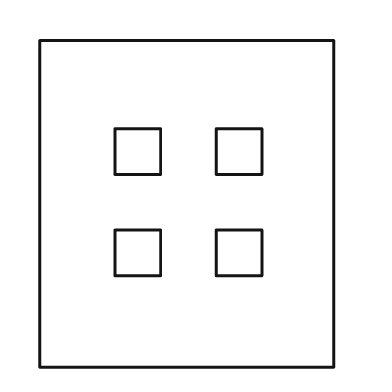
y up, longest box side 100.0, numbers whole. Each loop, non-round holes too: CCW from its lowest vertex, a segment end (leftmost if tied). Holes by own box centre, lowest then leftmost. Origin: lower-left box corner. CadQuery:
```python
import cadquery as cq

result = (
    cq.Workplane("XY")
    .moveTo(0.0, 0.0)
    .lineTo(90.0, 0.0)
    .lineTo(90.0, 100.0)
    .lineTo(0.0, 100.0)
    .close()
    .moveTo(23.0, 28.0)
    .lineTo(37.0, 28.0)
    .lineTo(37.0, 42.0)
    .lineTo(23.0, 42.0)
    .close()
    .moveTo(54.0, 28.0)
    .lineTo(68.0, 28.0)
    .lineTo(68.0, 42.0)
    .lineTo(54.0, 42.0)
    .close()
    .moveTo(23.0, 59.0)
    .lineTo(37.0, 59.0)
    .lineTo(37.0, 73.0)
    .lineTo(23.0, 73.0)
    .close()
    .moveTo(54.0, 59.0)
    .lineTo(68.0, 59.0)
    .lineTo(68.0, 73.0)
    .lineTo(54.0, 73.0)
    .close()
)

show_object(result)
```